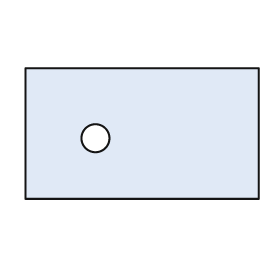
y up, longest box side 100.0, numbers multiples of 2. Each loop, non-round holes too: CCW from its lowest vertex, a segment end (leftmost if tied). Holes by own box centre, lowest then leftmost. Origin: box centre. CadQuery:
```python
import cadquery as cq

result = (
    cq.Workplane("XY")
    .moveTo(-50.0, -28.0)
    .lineTo(50.0, -28.0)
    .lineTo(50.0, 28.0)
    .lineTo(-50.0, 28.0)
    .close()
    .moveTo(-20.0, -2.0)
    .circle(6.0)
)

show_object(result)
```